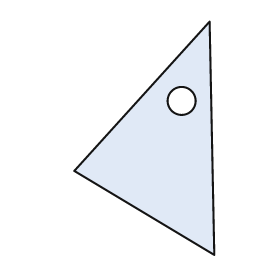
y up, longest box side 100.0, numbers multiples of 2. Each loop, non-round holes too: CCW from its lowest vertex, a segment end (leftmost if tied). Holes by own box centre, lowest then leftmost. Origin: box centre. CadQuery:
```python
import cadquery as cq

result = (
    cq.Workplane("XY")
    .moveTo(30.0, -50.0)
    .lineTo(28.0, 50.0)
    .lineTo(-30.0, -14.0)
    .close()
    .moveTo(16.0, 16.0)
    .circle(6.0)
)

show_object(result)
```